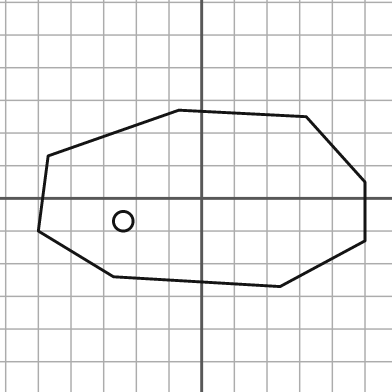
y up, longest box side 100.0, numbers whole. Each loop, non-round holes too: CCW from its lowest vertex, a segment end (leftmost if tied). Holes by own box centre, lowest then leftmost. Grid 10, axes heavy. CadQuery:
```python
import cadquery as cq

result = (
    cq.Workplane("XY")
    .moveTo(24.0, -27.0)
    .lineTo(50.0, -13.0)
    .lineTo(50.0, 5.0)
    .lineTo(32.0, 25.0)
    .lineTo(-7.0, 27.0)
    .lineTo(-47.0, 13.0)
    .lineTo(-50.0, -10.0)
    .lineTo(-27.0, -24.0)
    .close()
    .moveTo(-24.0, -7.0)
    .circle(3.0)
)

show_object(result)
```